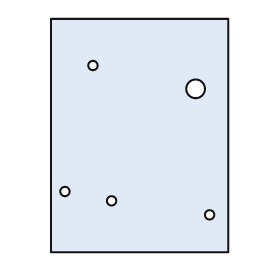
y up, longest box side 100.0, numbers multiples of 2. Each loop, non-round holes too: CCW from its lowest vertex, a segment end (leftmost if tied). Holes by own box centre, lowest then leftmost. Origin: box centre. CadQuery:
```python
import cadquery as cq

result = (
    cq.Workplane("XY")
    .moveTo(-38.0, -50.0)
    .lineTo(38.0, -50.0)
    .lineTo(38.0, 50.0)
    .lineTo(-38.0, 50.0)
    .close()
    .moveTo(30.0, -34.0)
    .circle(2.0)
    .moveTo(-12.0, -28.0)
    .circle(2.0)
    .moveTo(-32.0, -24.0)
    .circle(2.0)
    .moveTo(24.0, 20.0)
    .circle(4.0)
    .moveTo(-20.0, 30.0)
    .circle(2.0)
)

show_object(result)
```